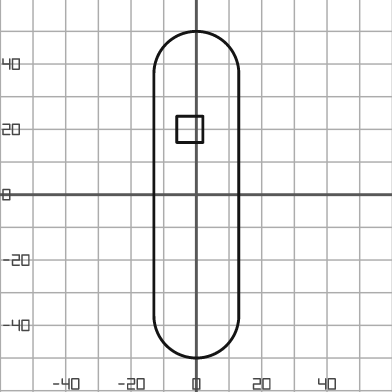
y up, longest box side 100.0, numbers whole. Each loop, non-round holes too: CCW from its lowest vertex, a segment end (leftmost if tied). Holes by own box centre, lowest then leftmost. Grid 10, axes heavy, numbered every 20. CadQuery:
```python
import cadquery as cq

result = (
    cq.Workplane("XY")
    .moveTo(-13.0, -37.0)
    .threePointArc((0.0, -50.0), (13.0, -37.0))
    .lineTo(13.0, 37.0)
    .threePointArc((0.0, 50.0), (-13.0, 37.0))
    .close()
    .moveTo(-6.0, 16.0)
    .lineTo(2.0, 16.0)
    .lineTo(2.0, 24.0)
    .lineTo(-6.0, 24.0)
    .close()
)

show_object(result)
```